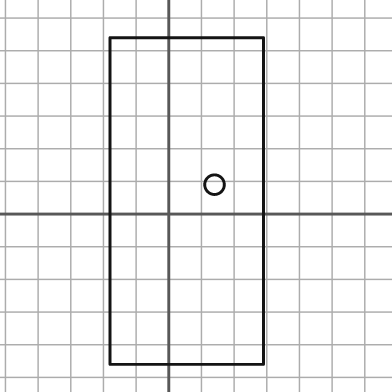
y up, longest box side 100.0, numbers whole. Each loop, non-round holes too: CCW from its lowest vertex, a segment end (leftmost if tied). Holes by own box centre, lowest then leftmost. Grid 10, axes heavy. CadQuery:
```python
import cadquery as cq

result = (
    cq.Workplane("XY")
    .moveTo(-18.0, -46.0)
    .lineTo(29.0, -46.0)
    .lineTo(29.0, 54.0)
    .lineTo(-18.0, 54.0)
    .close()
    .moveTo(14.0, 9.0)
    .circle(3.0)
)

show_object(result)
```